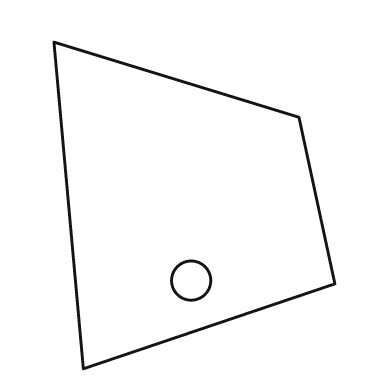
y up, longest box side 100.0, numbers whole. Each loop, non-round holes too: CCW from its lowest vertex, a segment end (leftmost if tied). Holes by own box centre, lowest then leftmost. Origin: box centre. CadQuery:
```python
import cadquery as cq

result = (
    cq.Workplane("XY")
    .moveTo(-34.0, -50.0)
    .lineTo(43.0, -24.0)
    .lineTo(32.0, 27.0)
    .lineTo(-43.0, 50.0)
    .close()
    .moveTo(-1.0, -23.0)
    .circle(6.0)
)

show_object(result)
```